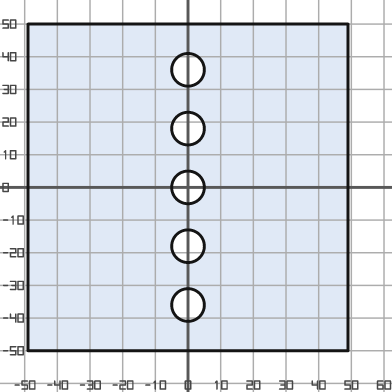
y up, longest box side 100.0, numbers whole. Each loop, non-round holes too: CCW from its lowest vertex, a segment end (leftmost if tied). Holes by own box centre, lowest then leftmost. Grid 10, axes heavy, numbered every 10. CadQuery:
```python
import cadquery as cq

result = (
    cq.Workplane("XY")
    .moveTo(-49.0, -50.0)
    .lineTo(49.0, -50.0)
    .lineTo(49.0, 50.0)
    .lineTo(-49.0, 50.0)
    .close()
    .moveTo(0.0, -36.0)
    .circle(5.0)
    .moveTo(0.0, -18.0)
    .circle(5.0)
    .moveTo(0.0, 0.0)
    .circle(5.0)
    .moveTo(0.0, 18.0)
    .circle(5.0)
    .moveTo(0.0, 36.0)
    .circle(5.0)
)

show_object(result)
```